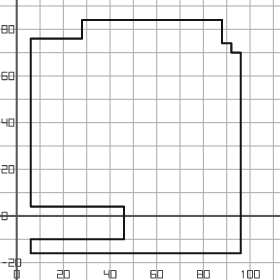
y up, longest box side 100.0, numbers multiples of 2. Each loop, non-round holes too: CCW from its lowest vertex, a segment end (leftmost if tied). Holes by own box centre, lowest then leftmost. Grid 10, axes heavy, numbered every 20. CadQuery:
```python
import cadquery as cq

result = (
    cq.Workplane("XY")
    .moveTo(6.0, -16.0)
    .lineTo(96.0, -16.0)
    .lineTo(96.0, 70.0)
    .lineTo(92.0, 70.0)
    .lineTo(92.0, 74.0)
    .lineTo(88.0, 74.0)
    .lineTo(88.0, 84.0)
    .lineTo(28.0, 84.0)
    .lineTo(28.0, 76.0)
    .lineTo(6.0, 76.0)
    .lineTo(6.0, 4.0)
    .lineTo(46.0, 4.0)
    .lineTo(46.0, -10.0)
    .lineTo(6.0, -10.0)
    .close()
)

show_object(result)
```